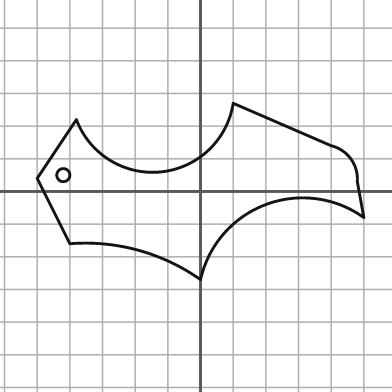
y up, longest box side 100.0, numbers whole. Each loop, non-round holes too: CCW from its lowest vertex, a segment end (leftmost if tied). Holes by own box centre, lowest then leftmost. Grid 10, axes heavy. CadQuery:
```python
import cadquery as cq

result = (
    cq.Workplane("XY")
    .moveTo(0.0, -27.0)
    .threePointArc((20.0, -4.0), (50.0, -8.0))
    .lineTo(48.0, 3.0)
    .threePointArc((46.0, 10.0), (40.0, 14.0))
    .lineTo(10.0, 27.0)
    .threePointArc((-12.0, 6.0), (-38.0, 22.0))
    .lineTo(-50.0, 4.0)
    .lineTo(-40.0, -16.0)
    .threePointArc((-19.0, -18.0), (0.0, -27.0))
    .close()
    .moveTo(-42.0, 5.0)
    .circle(2.0)
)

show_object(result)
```